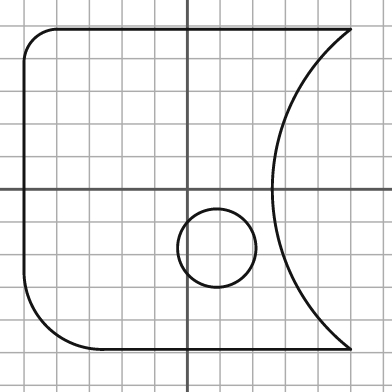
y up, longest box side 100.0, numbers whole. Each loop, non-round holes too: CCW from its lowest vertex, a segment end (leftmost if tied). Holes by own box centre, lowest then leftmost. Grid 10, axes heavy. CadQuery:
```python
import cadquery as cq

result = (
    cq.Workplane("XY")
    .moveTo(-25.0, -49.0)
    .lineTo(50.0, -49.0)
    .threePointArc((26.0, 0.0), (50.0, 49.0))
    .lineTo(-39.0, 49.0)
    .threePointArc((-47.0, 46.0), (-50.0, 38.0))
    .lineTo(-50.0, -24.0)
    .threePointArc((-43.0, -42.0), (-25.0, -49.0))
    .close()
    .moveTo(9.0, -18.0)
    .circle(12.0)
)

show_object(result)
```